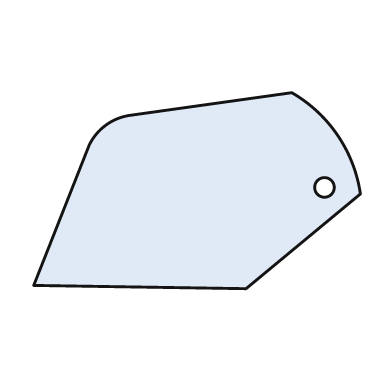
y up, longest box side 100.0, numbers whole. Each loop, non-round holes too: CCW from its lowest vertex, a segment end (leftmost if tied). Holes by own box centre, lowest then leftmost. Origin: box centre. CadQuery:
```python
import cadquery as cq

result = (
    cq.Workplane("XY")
    .moveTo(15.0, -30.0)
    .lineTo(50.0, -1.0)
    .threePointArc((43.0, 17.0), (29.0, 30.0))
    .lineTo(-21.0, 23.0)
    .threePointArc((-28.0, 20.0), (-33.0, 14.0))
    .lineTo(-50.0, -29.0)
    .close()
    .moveTo(39.0, 1.0)
    .circle(3.0)
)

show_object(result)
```